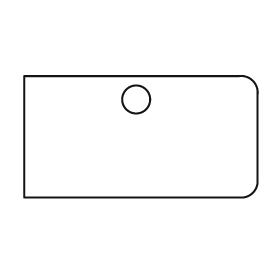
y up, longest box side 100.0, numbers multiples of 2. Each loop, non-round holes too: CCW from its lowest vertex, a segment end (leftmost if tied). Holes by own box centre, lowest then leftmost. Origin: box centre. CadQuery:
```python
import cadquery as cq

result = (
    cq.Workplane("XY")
    .moveTo(-50.0, -26.0)
    .lineTo(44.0, -26.0)
    .threePointArc((48.0, -24.0), (50.0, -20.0))
    .lineTo(50.0, 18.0)
    .threePointArc((48.0, 24.0), (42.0, 26.0))
    .lineTo(-50.0, 26.0)
    .close()
    .moveTo(-2.0, 16.0)
    .circle(6.0)
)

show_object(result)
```